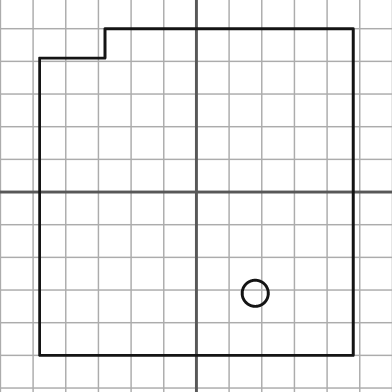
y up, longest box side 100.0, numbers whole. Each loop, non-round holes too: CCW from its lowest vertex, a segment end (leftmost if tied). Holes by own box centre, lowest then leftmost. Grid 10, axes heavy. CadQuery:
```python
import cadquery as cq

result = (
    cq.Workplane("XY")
    .moveTo(-48.0, -50.0)
    .lineTo(48.0, -50.0)
    .lineTo(48.0, 50.0)
    .lineTo(-28.0, 50.0)
    .lineTo(-28.0, 41.0)
    .lineTo(-48.0, 41.0)
    .close()
    .moveTo(18.0, -31.0)
    .circle(4.0)
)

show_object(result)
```